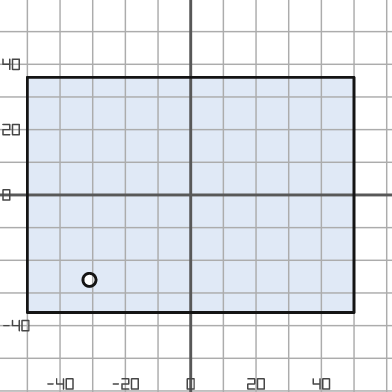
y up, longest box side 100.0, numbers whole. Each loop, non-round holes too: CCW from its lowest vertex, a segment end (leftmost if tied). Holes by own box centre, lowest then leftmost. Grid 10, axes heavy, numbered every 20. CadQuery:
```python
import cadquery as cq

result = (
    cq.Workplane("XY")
    .moveTo(-50.0, -36.0)
    .lineTo(50.0, -36.0)
    .lineTo(50.0, 36.0)
    .lineTo(-50.0, 36.0)
    .close()
    .moveTo(-31.0, -26.0)
    .circle(2.0)
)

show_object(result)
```